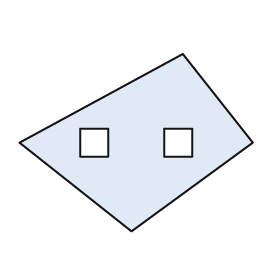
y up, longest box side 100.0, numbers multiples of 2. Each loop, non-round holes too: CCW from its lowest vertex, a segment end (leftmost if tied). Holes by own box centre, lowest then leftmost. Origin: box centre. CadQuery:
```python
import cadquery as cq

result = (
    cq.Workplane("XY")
    .moveTo(-2.0, -38.0)
    .lineTo(50.0, 0.0)
    .lineTo(20.0, 38.0)
    .lineTo(-50.0, 0.0)
    .close()
    .moveTo(-24.0, -6.0)
    .lineTo(-12.0, -6.0)
    .lineTo(-12.0, 6.0)
    .lineTo(-24.0, 6.0)
    .close()
    .moveTo(12.0, -6.0)
    .lineTo(24.0, -6.0)
    .lineTo(24.0, 6.0)
    .lineTo(12.0, 6.0)
    .close()
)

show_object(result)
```